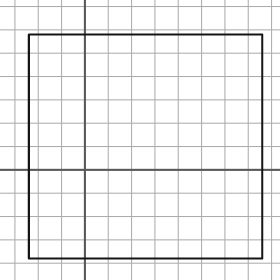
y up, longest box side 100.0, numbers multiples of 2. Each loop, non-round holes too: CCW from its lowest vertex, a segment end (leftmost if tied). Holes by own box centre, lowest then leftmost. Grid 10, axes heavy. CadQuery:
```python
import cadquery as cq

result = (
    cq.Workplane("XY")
    .moveTo(-24.0, -38.0)
    .lineTo(76.0, -38.0)
    .lineTo(76.0, 58.0)
    .lineTo(-24.0, 58.0)
    .close()
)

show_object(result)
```